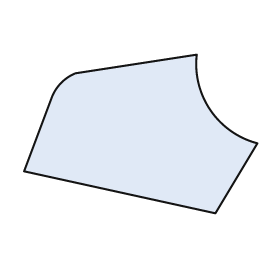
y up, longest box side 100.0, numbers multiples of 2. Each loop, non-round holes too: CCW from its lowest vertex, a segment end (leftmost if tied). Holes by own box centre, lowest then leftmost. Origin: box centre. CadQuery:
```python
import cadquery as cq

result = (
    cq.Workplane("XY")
    .moveTo(32.0, -34.0)
    .lineTo(50.0, -4.0)
    .threePointArc((30.0, 10.0), (24.0, 34.0))
    .lineTo(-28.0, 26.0)
    .threePointArc((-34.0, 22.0), (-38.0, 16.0))
    .lineTo(-50.0, -16.0)
    .close()
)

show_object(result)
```